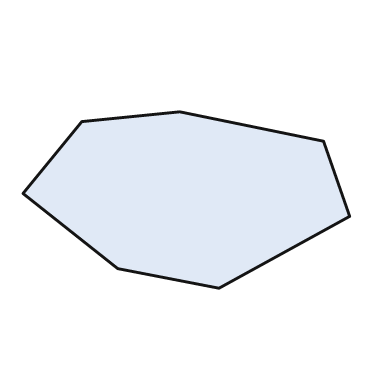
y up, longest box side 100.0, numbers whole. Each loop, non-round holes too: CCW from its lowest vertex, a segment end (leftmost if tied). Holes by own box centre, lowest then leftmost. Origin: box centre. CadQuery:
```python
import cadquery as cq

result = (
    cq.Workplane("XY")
    .moveTo(10.0, -27.0)
    .lineTo(50.0, -5.0)
    .lineTo(42.0, 18.0)
    .lineTo(-2.0, 27.0)
    .lineTo(-32.0, 24.0)
    .lineTo(-50.0, 2.0)
    .lineTo(-21.0, -21.0)
    .close()
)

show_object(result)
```